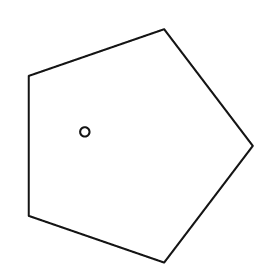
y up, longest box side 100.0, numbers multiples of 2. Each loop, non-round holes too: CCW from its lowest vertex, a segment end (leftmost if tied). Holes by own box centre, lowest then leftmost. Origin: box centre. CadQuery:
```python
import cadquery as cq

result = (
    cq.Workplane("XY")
    .moveTo(10.0, -50.0)
    .lineTo(48.0, 0.0)
    .lineTo(10.0, 50.0)
    .lineTo(-48.0, 30.0)
    .lineTo(-48.0, -30.0)
    .close()
    .moveTo(-24.0, 6.0)
    .circle(2.0)
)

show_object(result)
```